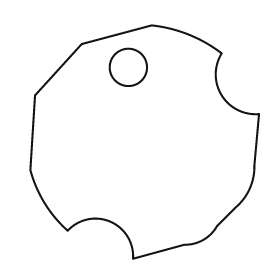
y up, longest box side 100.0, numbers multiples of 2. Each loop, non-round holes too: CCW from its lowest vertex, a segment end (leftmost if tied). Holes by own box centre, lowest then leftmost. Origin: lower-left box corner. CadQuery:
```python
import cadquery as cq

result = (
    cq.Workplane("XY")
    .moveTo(44.0, 0.0)
    .lineTo(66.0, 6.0)
    .threePointArc((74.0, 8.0), (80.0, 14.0))
    .lineTo(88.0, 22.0)
    .threePointArc((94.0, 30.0), (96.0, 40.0))
    .lineTo(98.0, 62.0)
    .threePointArc((82.0, 70.0), (82.0, 88.0))
    .threePointArc((68.0, 96.0), (52.0, 100.0))
    .lineTo(22.0, 92.0)
    .lineTo(2.0, 70.0)
    .lineTo(0.0, 38.0)
    .threePointArc((6.0, 24.0), (16.0, 12.0))
    .threePointArc((34.0, 16.0), (44.0, 0.0))
    .close()
    .moveTo(42.0, 82.0)
    .circle(8.0)
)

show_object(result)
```